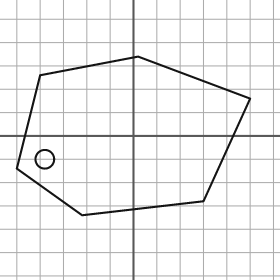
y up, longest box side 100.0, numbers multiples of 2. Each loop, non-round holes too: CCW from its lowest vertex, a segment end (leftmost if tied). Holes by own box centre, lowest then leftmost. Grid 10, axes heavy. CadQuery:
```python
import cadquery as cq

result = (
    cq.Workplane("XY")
    .moveTo(-22.0, -34.0)
    .lineTo(30.0, -28.0)
    .lineTo(50.0, 16.0)
    .lineTo(2.0, 34.0)
    .lineTo(-40.0, 26.0)
    .lineTo(-50.0, -14.0)
    .close()
    .moveTo(-38.0, -10.0)
    .circle(4.0)
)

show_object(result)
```